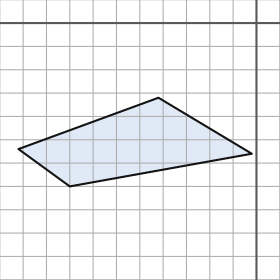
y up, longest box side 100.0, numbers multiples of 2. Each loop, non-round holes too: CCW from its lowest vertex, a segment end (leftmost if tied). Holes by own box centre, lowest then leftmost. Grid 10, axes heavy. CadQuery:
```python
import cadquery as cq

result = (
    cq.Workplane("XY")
    .moveTo(-80.0, -70.0)
    .lineTo(-2.0, -56.0)
    .lineTo(-42.0, -32.0)
    .lineTo(-102.0, -54.0)
    .close()
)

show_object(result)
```